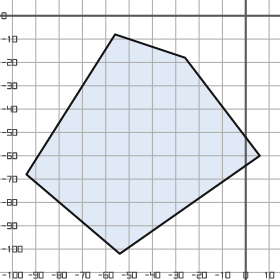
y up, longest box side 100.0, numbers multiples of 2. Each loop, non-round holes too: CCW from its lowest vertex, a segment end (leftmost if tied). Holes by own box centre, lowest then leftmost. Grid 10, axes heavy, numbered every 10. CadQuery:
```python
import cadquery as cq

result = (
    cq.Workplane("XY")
    .moveTo(-54.0, -102.0)
    .lineTo(6.0, -60.0)
    .lineTo(-26.0, -18.0)
    .lineTo(-56.0, -8.0)
    .lineTo(-94.0, -68.0)
    .close()
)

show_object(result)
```